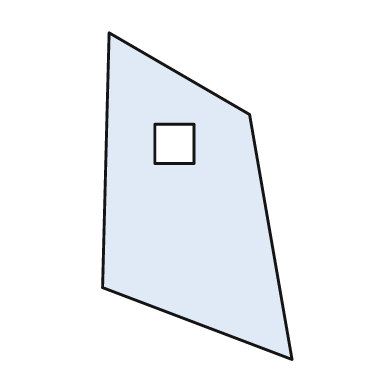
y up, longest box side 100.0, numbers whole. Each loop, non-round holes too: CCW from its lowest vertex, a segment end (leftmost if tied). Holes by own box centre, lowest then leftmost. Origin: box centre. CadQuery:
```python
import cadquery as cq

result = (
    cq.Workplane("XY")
    .moveTo(29.0, -50.0)
    .lineTo(16.0, 25.0)
    .lineTo(-27.0, 50.0)
    .lineTo(-29.0, -28.0)
    .close()
    .moveTo(-13.0, 10.0)
    .lineTo(-1.0, 10.0)
    .lineTo(-1.0, 22.0)
    .lineTo(-13.0, 22.0)
    .close()
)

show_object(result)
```